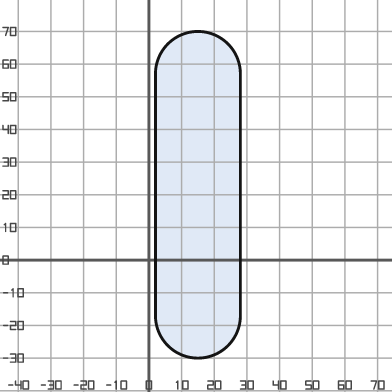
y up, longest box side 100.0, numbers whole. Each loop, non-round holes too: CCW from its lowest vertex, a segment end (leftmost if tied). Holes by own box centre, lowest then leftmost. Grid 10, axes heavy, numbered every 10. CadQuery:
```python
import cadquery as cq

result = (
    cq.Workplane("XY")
    .moveTo(2.0, -17.0)
    .threePointArc((15.0, -30.0), (28.0, -17.0))
    .lineTo(28.0, 57.0)
    .threePointArc((15.0, 70.0), (2.0, 57.0))
    .close()
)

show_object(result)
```